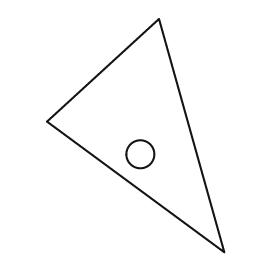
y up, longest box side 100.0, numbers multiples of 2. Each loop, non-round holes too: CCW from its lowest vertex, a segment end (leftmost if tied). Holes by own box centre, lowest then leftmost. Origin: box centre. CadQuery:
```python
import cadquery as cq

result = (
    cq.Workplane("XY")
    .moveTo(38.0, -50.0)
    .lineTo(10.0, 50.0)
    .lineTo(-38.0, 6.0)
    .close()
    .moveTo(2.0, -8.0)
    .circle(6.0)
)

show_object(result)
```